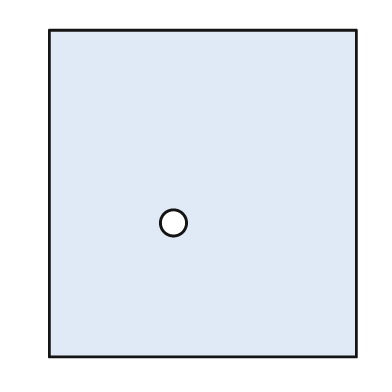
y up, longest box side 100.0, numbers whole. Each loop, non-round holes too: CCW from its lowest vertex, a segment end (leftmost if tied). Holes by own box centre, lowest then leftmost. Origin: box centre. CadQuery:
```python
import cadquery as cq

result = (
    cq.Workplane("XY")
    .moveTo(-47.0, -50.0)
    .lineTo(47.0, -50.0)
    .lineTo(47.0, 50.0)
    .lineTo(-47.0, 50.0)
    .close()
    .moveTo(-9.0, -9.0)
    .circle(4.0)
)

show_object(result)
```